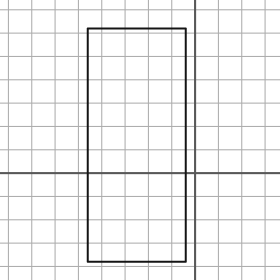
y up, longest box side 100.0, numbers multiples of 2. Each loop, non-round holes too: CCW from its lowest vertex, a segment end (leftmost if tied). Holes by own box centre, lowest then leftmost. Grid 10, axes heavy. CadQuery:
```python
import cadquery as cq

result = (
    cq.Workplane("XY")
    .moveTo(-46.0, -38.0)
    .lineTo(-4.0, -38.0)
    .lineTo(-4.0, 62.0)
    .lineTo(-46.0, 62.0)
    .close()
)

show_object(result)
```